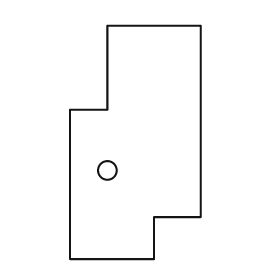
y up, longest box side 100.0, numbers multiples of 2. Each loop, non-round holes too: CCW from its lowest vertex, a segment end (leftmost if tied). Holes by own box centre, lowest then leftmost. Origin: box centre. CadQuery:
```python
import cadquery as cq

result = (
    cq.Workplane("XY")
    .moveTo(-28.0, -50.0)
    .lineTo(8.0, -50.0)
    .lineTo(8.0, -32.0)
    .lineTo(28.0, -32.0)
    .lineTo(28.0, 50.0)
    .lineTo(-12.0, 50.0)
    .lineTo(-12.0, 14.0)
    .lineTo(-28.0, 14.0)
    .close()
    .moveTo(-12.0, -12.0)
    .circle(4.0)
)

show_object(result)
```